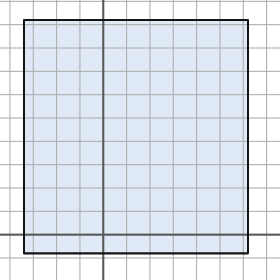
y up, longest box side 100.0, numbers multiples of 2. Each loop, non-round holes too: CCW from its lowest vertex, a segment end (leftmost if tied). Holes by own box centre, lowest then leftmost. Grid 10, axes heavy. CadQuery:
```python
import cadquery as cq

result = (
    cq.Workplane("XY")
    .moveTo(-34.0, -8.0)
    .lineTo(62.0, -8.0)
    .lineTo(62.0, 92.0)
    .lineTo(-34.0, 92.0)
    .close()
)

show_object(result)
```